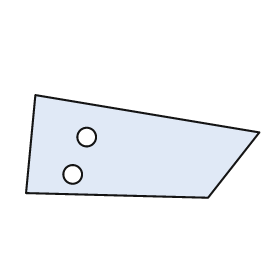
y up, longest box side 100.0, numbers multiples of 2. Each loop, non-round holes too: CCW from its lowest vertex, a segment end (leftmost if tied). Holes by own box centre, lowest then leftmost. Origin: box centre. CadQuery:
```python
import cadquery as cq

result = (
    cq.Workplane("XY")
    .moveTo(28.0, -22.0)
    .lineTo(50.0, 6.0)
    .lineTo(-46.0, 22.0)
    .lineTo(-50.0, -20.0)
    .close()
    .moveTo(-30.0, -12.0)
    .circle(4.0)
    .moveTo(-24.0, 4.0)
    .circle(4.0)
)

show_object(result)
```